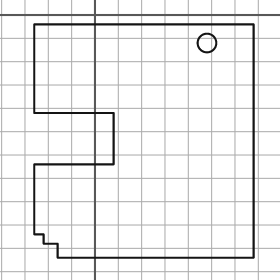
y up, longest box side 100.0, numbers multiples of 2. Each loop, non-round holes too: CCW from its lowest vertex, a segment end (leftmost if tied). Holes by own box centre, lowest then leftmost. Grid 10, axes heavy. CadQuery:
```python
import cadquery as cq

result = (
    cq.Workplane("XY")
    .moveTo(-16.0, -104.0)
    .lineTo(68.0, -104.0)
    .lineTo(68.0, -4.0)
    .lineTo(-26.0, -4.0)
    .lineTo(-26.0, -42.0)
    .lineTo(8.0, -42.0)
    .lineTo(8.0, -64.0)
    .lineTo(-26.0, -64.0)
    .lineTo(-26.0, -94.0)
    .lineTo(-22.0, -94.0)
    .lineTo(-22.0, -98.0)
    .lineTo(-16.0, -98.0)
    .close()
    .moveTo(48.0, -12.0)
    .circle(4.0)
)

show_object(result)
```